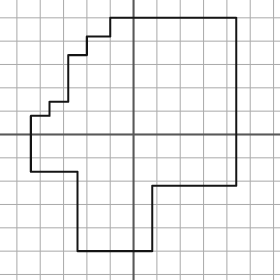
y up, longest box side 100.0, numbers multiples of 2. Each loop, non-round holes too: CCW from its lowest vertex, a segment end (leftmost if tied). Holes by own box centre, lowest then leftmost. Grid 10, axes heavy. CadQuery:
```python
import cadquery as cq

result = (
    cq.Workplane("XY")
    .moveTo(-24.0, -50.0)
    .lineTo(8.0, -50.0)
    .lineTo(8.0, -22.0)
    .lineTo(44.0, -22.0)
    .lineTo(44.0, 50.0)
    .lineTo(-10.0, 50.0)
    .lineTo(-10.0, 42.0)
    .lineTo(-20.0, 42.0)
    .lineTo(-20.0, 34.0)
    .lineTo(-28.0, 34.0)
    .lineTo(-28.0, 14.0)
    .lineTo(-36.0, 14.0)
    .lineTo(-36.0, 8.0)
    .lineTo(-44.0, 8.0)
    .lineTo(-44.0, -16.0)
    .lineTo(-24.0, -16.0)
    .close()
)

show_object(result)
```